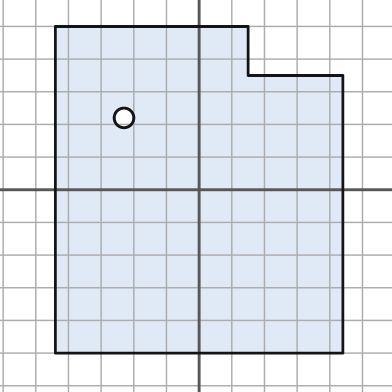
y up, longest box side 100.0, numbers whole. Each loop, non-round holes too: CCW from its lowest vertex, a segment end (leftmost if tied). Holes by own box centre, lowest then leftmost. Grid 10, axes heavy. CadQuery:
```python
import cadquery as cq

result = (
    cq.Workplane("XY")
    .moveTo(-44.0, -50.0)
    .lineTo(44.0, -50.0)
    .lineTo(44.0, 35.0)
    .lineTo(15.0, 35.0)
    .lineTo(15.0, 50.0)
    .lineTo(-44.0, 50.0)
    .close()
    .moveTo(-23.0, 22.0)
    .circle(3.0)
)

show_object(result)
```